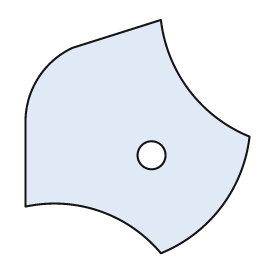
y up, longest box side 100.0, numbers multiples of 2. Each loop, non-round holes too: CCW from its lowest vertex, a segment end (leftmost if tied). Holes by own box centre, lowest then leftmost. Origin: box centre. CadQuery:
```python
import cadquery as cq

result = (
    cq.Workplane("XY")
    .moveTo(10.0, -50.0)
    .threePointArc((36.0, -30.0), (48.0, 0.0))
    .threePointArc((22.0, 20.0), (10.0, 50.0))
    .lineTo(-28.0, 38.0)
    .threePointArc((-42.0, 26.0), (-48.0, 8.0))
    .lineTo(-48.0, -30.0)
    .threePointArc((-16.0, -32.0), (10.0, -50.0))
    .close()
    .moveTo(6.0, -8.0)
    .circle(6.0)
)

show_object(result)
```